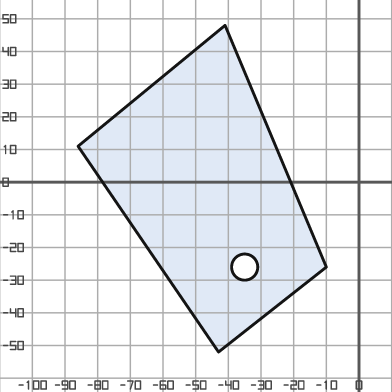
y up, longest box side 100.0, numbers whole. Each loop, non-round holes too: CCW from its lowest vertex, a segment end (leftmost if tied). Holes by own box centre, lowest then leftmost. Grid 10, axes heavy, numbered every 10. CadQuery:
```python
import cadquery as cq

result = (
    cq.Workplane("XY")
    .moveTo(-43.0, -52.0)
    .lineTo(-10.0, -26.0)
    .lineTo(-41.0, 48.0)
    .lineTo(-86.0, 11.0)
    .close()
    .moveTo(-35.0, -26.0)
    .circle(4.0)
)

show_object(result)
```